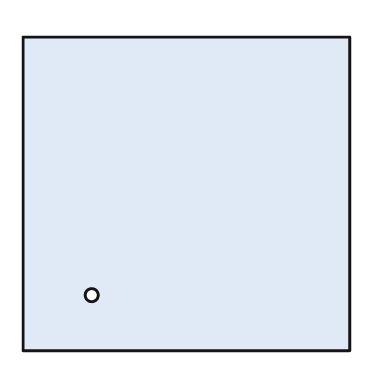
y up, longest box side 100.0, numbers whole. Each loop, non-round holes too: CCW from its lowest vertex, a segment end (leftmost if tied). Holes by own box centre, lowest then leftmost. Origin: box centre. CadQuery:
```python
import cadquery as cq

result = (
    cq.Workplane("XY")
    .moveTo(-50.0, -48.0)
    .lineTo(50.0, -48.0)
    .lineTo(50.0, 48.0)
    .lineTo(-50.0, 48.0)
    .close()
    .moveTo(-29.0, -31.0)
    .circle(2.0)
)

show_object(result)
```